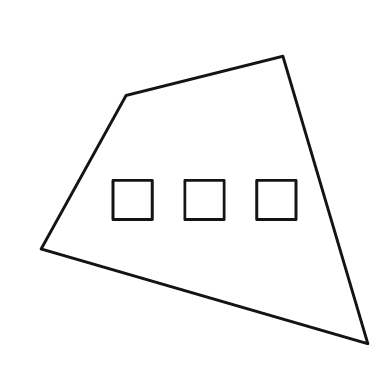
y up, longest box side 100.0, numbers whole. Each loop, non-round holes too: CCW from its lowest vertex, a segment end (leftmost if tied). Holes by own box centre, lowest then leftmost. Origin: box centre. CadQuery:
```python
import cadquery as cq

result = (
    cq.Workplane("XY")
    .moveTo(50.0, -44.0)
    .lineTo(24.0, 44.0)
    .lineTo(-24.0, 32.0)
    .lineTo(-50.0, -15.0)
    .close()
    .moveTo(-28.0, -6.0)
    .lineTo(-16.0, -6.0)
    .lineTo(-16.0, 6.0)
    .lineTo(-28.0, 6.0)
    .close()
    .moveTo(-6.0, -6.0)
    .lineTo(6.0, -6.0)
    .lineTo(6.0, 6.0)
    .lineTo(-6.0, 6.0)
    .close()
    .moveTo(16.0, -6.0)
    .lineTo(28.0, -6.0)
    .lineTo(28.0, 6.0)
    .lineTo(16.0, 6.0)
    .close()
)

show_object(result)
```